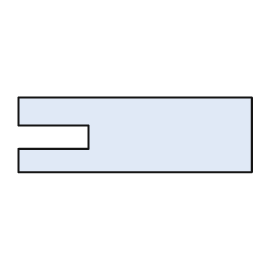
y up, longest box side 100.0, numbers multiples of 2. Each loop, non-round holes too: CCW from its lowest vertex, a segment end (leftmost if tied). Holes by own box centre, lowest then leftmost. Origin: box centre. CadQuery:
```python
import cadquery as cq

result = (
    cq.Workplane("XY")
    .moveTo(-50.0, -16.0)
    .lineTo(50.0, -16.0)
    .lineTo(50.0, 16.0)
    .lineTo(-50.0, 16.0)
    .lineTo(-50.0, 4.0)
    .lineTo(-20.0, 4.0)
    .lineTo(-20.0, -6.0)
    .lineTo(-50.0, -6.0)
    .close()
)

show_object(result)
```